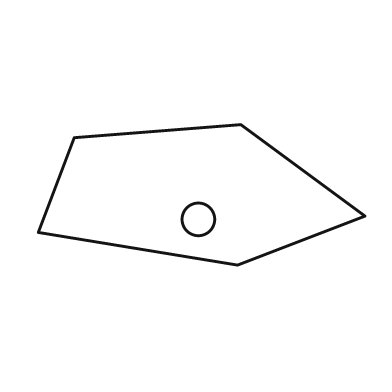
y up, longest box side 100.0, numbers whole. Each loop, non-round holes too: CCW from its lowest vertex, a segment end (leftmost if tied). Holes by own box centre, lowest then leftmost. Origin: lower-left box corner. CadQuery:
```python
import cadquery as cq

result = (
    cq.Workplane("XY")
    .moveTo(61.0, 0.0)
    .lineTo(100.0, 15.0)
    .lineTo(62.0, 43.0)
    .lineTo(11.0, 39.0)
    .lineTo(0.0, 10.0)
    .close()
    .moveTo(49.0, 14.0)
    .circle(5.0)
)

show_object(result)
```